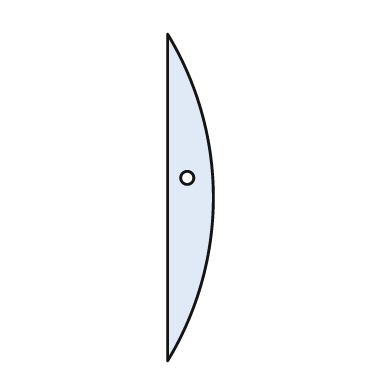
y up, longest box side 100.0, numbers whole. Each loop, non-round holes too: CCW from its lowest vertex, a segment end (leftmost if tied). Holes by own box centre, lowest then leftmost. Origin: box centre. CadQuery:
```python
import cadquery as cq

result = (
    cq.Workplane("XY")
    .moveTo(-7.0, -50.0)
    .threePointArc((7.0, 0.0), (-7.0, 50.0))
    .close()
    .moveTo(-1.0, 6.0)
    .circle(2.0)
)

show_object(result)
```